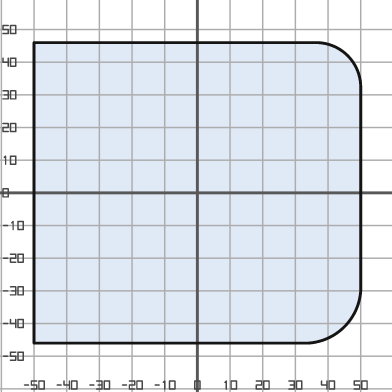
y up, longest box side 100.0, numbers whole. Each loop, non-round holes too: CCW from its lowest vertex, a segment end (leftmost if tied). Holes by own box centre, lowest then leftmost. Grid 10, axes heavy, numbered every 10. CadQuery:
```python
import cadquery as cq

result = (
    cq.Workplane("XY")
    .moveTo(-50.0, -46.0)
    .lineTo(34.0, -46.0)
    .threePointArc((45.0, -41.0), (50.0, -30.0))
    .lineTo(50.0, 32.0)
    .threePointArc((46.0, 42.0), (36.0, 46.0))
    .lineTo(-50.0, 46.0)
    .close()
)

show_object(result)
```